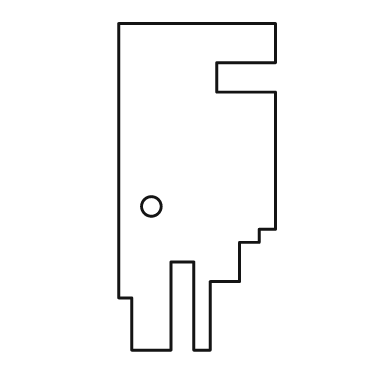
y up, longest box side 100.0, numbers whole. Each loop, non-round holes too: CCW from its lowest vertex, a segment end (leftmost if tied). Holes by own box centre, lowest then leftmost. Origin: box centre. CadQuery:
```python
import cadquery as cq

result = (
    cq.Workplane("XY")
    .moveTo(-20.0, -50.0)
    .lineTo(-8.0, -50.0)
    .lineTo(-8.0, -23.0)
    .lineTo(-1.0, -23.0)
    .lineTo(-1.0, -50.0)
    .lineTo(4.0, -50.0)
    .lineTo(4.0, -29.0)
    .lineTo(13.0, -29.0)
    .lineTo(13.0, -17.0)
    .lineTo(19.0, -17.0)
    .lineTo(19.0, -13.0)
    .lineTo(24.0, -13.0)
    .lineTo(24.0, 29.0)
    .lineTo(6.0, 29.0)
    .lineTo(6.0, 38.0)
    .lineTo(24.0, 38.0)
    .lineTo(24.0, 50.0)
    .lineTo(-24.0, 50.0)
    .lineTo(-24.0, -34.0)
    .lineTo(-20.0, -34.0)
    .close()
    .moveTo(-14.0, -6.0)
    .circle(3.0)
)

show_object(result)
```